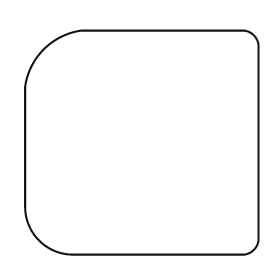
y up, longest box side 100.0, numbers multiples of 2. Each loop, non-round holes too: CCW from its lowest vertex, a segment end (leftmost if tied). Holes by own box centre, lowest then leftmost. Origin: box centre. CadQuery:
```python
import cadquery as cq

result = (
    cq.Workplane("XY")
    .moveTo(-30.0, -48.0)
    .lineTo(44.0, -48.0)
    .threePointArc((48.0, -46.0), (50.0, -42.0))
    .lineTo(50.0, 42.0)
    .threePointArc((48.0, 46.0), (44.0, 48.0))
    .lineTo(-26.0, 48.0)
    .threePointArc((-42.0, 40.0), (-50.0, 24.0))
    .lineTo(-50.0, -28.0)
    .threePointArc((-44.0, -42.0), (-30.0, -48.0))
    .close()
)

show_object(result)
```